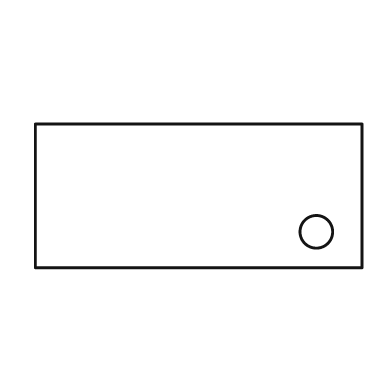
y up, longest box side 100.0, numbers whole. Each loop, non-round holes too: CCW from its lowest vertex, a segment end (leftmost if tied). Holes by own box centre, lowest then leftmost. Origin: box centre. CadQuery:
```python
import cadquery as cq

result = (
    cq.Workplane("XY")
    .moveTo(-50.0, -22.0)
    .lineTo(50.0, -22.0)
    .lineTo(50.0, 22.0)
    .lineTo(-50.0, 22.0)
    .close()
    .moveTo(36.0, -11.0)
    .circle(5.0)
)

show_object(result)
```